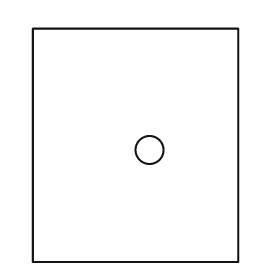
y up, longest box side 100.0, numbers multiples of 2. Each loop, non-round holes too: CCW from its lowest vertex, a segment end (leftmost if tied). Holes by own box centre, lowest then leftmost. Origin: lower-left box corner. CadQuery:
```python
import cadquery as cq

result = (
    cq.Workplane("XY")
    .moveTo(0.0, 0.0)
    .lineTo(88.0, 0.0)
    .lineTo(88.0, 100.0)
    .lineTo(0.0, 100.0)
    .close()
    .moveTo(50.0, 48.0)
    .circle(6.0)
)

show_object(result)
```